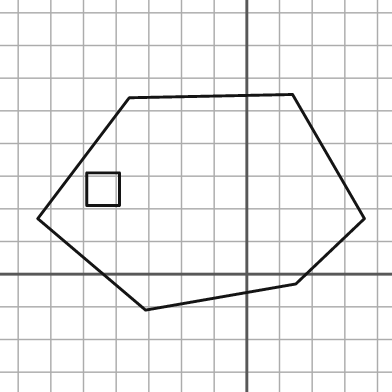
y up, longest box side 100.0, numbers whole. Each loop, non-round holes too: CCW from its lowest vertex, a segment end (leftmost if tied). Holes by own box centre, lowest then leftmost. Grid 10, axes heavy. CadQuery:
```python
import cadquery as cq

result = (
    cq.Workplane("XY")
    .moveTo(-31.0, -11.0)
    .lineTo(15.0, -3.0)
    .lineTo(36.0, 17.0)
    .lineTo(14.0, 55.0)
    .lineTo(-36.0, 54.0)
    .lineTo(-64.0, 17.0)
    .close()
    .moveTo(-49.0, 21.0)
    .lineTo(-39.0, 21.0)
    .lineTo(-39.0, 31.0)
    .lineTo(-49.0, 31.0)
    .close()
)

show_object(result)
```